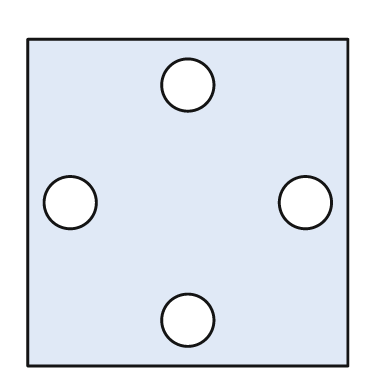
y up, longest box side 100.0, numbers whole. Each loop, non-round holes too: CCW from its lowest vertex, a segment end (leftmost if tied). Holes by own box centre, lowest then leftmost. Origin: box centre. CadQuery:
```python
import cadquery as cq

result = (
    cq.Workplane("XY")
    .moveTo(-49.0, -50.0)
    .lineTo(49.0, -50.0)
    .lineTo(49.0, 50.0)
    .lineTo(-49.0, 50.0)
    .close()
    .moveTo(0.0, -36.0)
    .circle(8.0)
    .moveTo(-36.0, 0.0)
    .circle(8.0)
    .moveTo(36.0, 0.0)
    .circle(8.0)
    .moveTo(0.0, 36.0)
    .circle(8.0)
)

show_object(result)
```